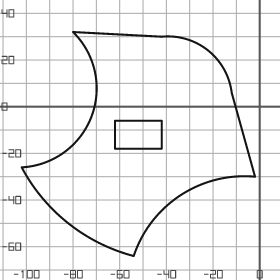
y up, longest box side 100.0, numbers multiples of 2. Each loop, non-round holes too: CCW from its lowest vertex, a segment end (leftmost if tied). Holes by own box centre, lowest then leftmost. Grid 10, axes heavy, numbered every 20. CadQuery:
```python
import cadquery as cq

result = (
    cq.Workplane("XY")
    .moveTo(-54.0, -64.0)
    .threePointArc((-34.0, -38.0), (-2.0, -30.0))
    .lineTo(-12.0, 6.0)
    .threePointArc((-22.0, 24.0), (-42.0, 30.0))
    .lineTo(-80.0, 32.0)
    .threePointArc((-72.0, -4.0), (-102.0, -26.0))
    .threePointArc((-82.0, -50.0), (-54.0, -64.0))
    .close()
    .moveTo(-62.0, -18.0)
    .lineTo(-42.0, -18.0)
    .lineTo(-42.0, -6.0)
    .lineTo(-62.0, -6.0)
    .close()
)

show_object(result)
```